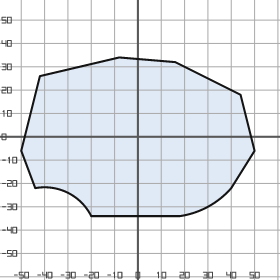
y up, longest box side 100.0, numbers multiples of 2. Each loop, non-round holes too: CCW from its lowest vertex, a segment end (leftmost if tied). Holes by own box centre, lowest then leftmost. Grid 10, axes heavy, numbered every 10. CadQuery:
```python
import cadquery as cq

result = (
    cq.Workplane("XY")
    .moveTo(-20.0, -34.0)
    .lineTo(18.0, -34.0)
    .threePointArc((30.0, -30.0), (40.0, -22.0))
    .lineTo(50.0, -6.0)
    .lineTo(44.0, 18.0)
    .lineTo(16.0, 32.0)
    .lineTo(-8.0, 34.0)
    .lineTo(-42.0, 26.0)
    .lineTo(-50.0, -6.0)
    .lineTo(-44.0, -22.0)
    .threePointArc((-30.0, -24.0), (-20.0, -34.0))
    .close()
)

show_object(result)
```